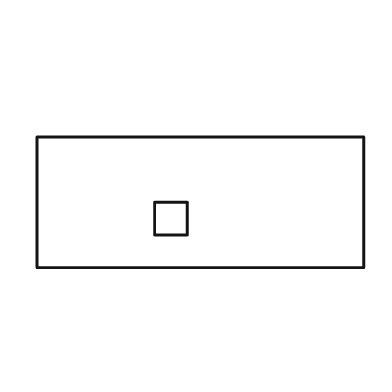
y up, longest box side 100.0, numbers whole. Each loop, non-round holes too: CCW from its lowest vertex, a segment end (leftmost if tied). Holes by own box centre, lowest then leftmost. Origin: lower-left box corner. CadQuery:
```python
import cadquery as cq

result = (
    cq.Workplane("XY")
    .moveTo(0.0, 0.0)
    .lineTo(100.0, 0.0)
    .lineTo(100.0, 40.0)
    .lineTo(0.0, 40.0)
    .close()
    .moveTo(36.0, 10.0)
    .lineTo(46.0, 10.0)
    .lineTo(46.0, 20.0)
    .lineTo(36.0, 20.0)
    .close()
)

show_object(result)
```